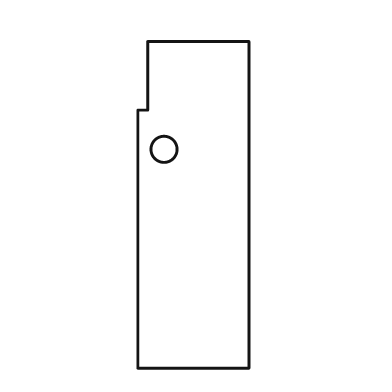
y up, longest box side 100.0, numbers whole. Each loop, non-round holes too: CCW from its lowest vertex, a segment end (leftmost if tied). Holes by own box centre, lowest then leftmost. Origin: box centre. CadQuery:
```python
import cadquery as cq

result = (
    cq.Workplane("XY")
    .moveTo(-17.0, -50.0)
    .lineTo(17.0, -50.0)
    .lineTo(17.0, 50.0)
    .lineTo(-14.0, 50.0)
    .lineTo(-14.0, 29.0)
    .lineTo(-17.0, 29.0)
    .close()
    .moveTo(-9.0, 17.0)
    .circle(4.0)
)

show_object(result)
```